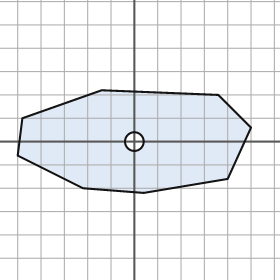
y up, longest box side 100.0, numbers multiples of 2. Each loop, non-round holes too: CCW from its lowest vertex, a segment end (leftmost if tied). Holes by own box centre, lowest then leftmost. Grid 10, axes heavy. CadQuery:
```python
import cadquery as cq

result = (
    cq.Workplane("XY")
    .moveTo(4.0, -22.0)
    .lineTo(40.0, -16.0)
    .lineTo(50.0, 6.0)
    .lineTo(36.0, 20.0)
    .lineTo(-14.0, 22.0)
    .lineTo(-48.0, 10.0)
    .lineTo(-50.0, -6.0)
    .lineTo(-22.0, -20.0)
    .close()
    .moveTo(0.0, 0.0)
    .circle(4.0)
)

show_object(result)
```